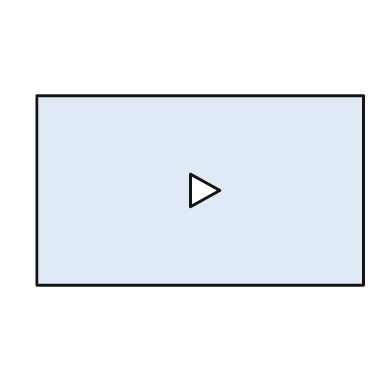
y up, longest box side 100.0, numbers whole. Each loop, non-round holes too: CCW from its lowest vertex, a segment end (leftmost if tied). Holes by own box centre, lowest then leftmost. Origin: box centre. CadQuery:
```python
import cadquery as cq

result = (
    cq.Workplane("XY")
    .moveTo(-50.0, -29.0)
    .lineTo(50.0, -29.0)
    .lineTo(50.0, 29.0)
    .lineTo(-50.0, 29.0)
    .close()
    .moveTo(-3.0, -5.0)
    .lineTo(6.0, 0.0)
    .lineTo(-3.0, 5.0)
    .close()
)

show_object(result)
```